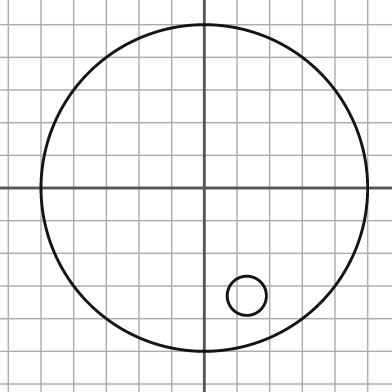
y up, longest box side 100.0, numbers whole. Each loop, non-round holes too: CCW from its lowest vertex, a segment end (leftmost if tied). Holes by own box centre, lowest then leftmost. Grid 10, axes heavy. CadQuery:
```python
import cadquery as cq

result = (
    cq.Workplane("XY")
    .moveTo(0.0, 0.0)
    .circle(50.0)
    .moveTo(13.0, -33.0)
    .circle(6.0)
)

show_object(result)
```